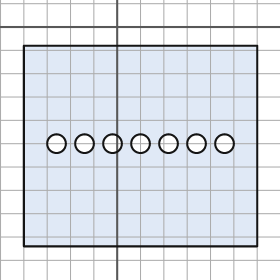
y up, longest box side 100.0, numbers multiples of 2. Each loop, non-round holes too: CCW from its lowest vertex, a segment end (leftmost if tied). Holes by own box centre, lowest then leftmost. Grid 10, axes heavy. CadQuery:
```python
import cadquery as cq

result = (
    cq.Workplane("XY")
    .moveTo(-40.0, -94.0)
    .lineTo(60.0, -94.0)
    .lineTo(60.0, -8.0)
    .lineTo(-40.0, -8.0)
    .close()
    .moveTo(-26.0, -50.0)
    .circle(4.0)
    .moveTo(-14.0, -50.0)
    .circle(4.0)
    .moveTo(-2.0, -50.0)
    .circle(4.0)
    .moveTo(10.0, -50.0)
    .circle(4.0)
    .moveTo(22.0, -50.0)
    .circle(4.0)
    .moveTo(34.0, -50.0)
    .circle(4.0)
    .moveTo(46.0, -50.0)
    .circle(4.0)
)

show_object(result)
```